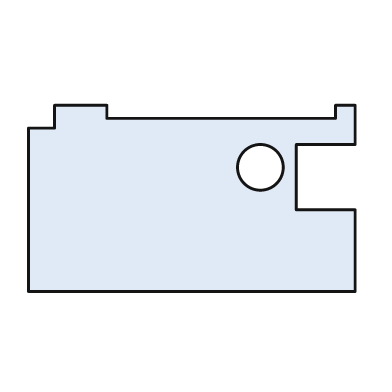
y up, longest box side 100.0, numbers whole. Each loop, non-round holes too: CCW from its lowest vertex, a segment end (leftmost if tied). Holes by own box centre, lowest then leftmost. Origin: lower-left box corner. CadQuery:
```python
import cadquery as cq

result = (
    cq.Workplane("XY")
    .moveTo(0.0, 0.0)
    .lineTo(100.0, 0.0)
    .lineTo(100.0, 25.0)
    .lineTo(82.0, 25.0)
    .lineTo(82.0, 45.0)
    .lineTo(100.0, 45.0)
    .lineTo(100.0, 57.0)
    .lineTo(94.0, 57.0)
    .lineTo(94.0, 53.0)
    .lineTo(24.0, 53.0)
    .lineTo(24.0, 57.0)
    .lineTo(8.0, 57.0)
    .lineTo(8.0, 50.0)
    .lineTo(0.0, 50.0)
    .close()
    .moveTo(71.0, 38.0)
    .circle(7.0)
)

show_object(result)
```